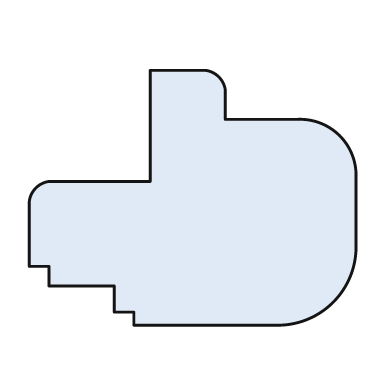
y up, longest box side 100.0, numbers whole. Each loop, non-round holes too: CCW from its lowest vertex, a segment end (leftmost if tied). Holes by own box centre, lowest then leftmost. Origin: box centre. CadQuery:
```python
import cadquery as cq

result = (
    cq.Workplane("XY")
    .moveTo(-18.0, -39.0)
    .lineTo(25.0, -39.0)
    .threePointArc((43.0, -32.0), (50.0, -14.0))
    .lineTo(50.0, 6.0)
    .threePointArc((45.0, 19.0), (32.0, 24.0))
    .lineTo(10.0, 24.0)
    .lineTo(10.0, 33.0)
    .threePointArc((8.0, 37.0), (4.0, 39.0))
    .lineTo(-13.0, 39.0)
    .lineTo(-13.0, 5.0)
    .lineTo(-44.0, 5.0)
    .threePointArc((-48.0, 3.0), (-50.0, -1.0))
    .lineTo(-50.0, -21.0)
    .lineTo(-44.0, -21.0)
    .lineTo(-44.0, -27.0)
    .lineTo(-24.0, -27.0)
    .lineTo(-24.0, -35.0)
    .lineTo(-18.0, -35.0)
    .close()
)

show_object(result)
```